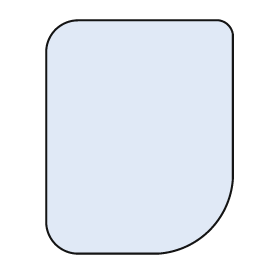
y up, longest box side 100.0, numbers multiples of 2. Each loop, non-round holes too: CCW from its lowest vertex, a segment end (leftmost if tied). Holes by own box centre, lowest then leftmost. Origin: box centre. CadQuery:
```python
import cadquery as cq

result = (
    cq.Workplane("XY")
    .moveTo(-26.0, -50.0)
    .lineTo(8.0, -50.0)
    .threePointArc((30.0, -40.0), (40.0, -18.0))
    .lineTo(40.0, 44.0)
    .threePointArc((38.0, 48.0), (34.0, 50.0))
    .lineTo(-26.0, 50.0)
    .threePointArc((-36.0, 46.0), (-40.0, 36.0))
    .lineTo(-40.0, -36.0)
    .threePointArc((-36.0, -46.0), (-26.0, -50.0))
    .close()
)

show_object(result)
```